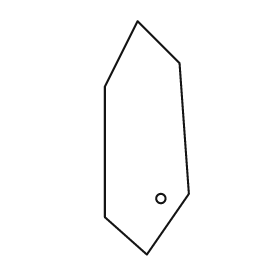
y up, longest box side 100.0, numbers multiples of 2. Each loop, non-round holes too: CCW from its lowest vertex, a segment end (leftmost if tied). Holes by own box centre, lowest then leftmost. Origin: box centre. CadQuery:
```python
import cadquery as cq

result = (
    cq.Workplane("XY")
    .moveTo(0.0, -50.0)
    .lineTo(18.0, -24.0)
    .lineTo(14.0, 32.0)
    .lineTo(-4.0, 50.0)
    .lineTo(-18.0, 22.0)
    .lineTo(-18.0, -34.0)
    .close()
    .moveTo(6.0, -26.0)
    .circle(2.0)
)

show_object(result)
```